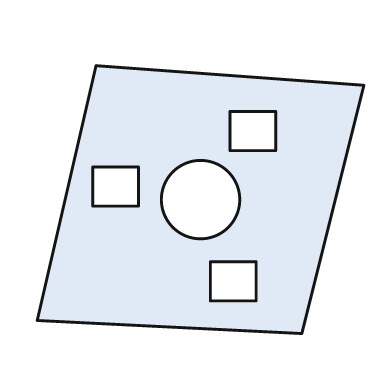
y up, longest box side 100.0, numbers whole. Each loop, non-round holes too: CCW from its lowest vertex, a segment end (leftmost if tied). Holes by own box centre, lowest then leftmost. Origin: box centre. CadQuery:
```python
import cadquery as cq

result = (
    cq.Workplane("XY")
    .moveTo(31.0, -41.0)
    .lineTo(50.0, 35.0)
    .lineTo(-32.0, 41.0)
    .lineTo(-50.0, -37.0)
    .close()
    .moveTo(3.0, -31.0)
    .lineTo(17.0, -31.0)
    .lineTo(17.0, -19.0)
    .lineTo(3.0, -19.0)
    .close()
    .moveTo(0.0, 0.0)
    .circle(12.0)
    .moveTo(-33.0, -2.0)
    .lineTo(-19.0, -2.0)
    .lineTo(-19.0, 10.0)
    .lineTo(-33.0, 10.0)
    .close()
    .moveTo(9.0, 15.0)
    .lineTo(23.0, 15.0)
    .lineTo(23.0, 27.0)
    .lineTo(9.0, 27.0)
    .close()
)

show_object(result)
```